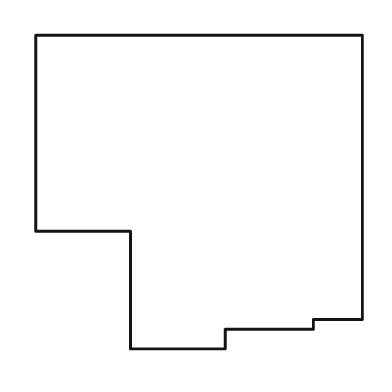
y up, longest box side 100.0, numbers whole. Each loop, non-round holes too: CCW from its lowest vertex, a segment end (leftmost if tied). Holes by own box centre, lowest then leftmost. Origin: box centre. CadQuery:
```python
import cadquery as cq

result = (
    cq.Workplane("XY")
    .moveTo(-21.0, -48.0)
    .lineTo(8.0, -48.0)
    .lineTo(8.0, -42.0)
    .lineTo(35.0, -42.0)
    .lineTo(35.0, -39.0)
    .lineTo(50.0, -39.0)
    .lineTo(50.0, 48.0)
    .lineTo(-50.0, 48.0)
    .lineTo(-50.0, -12.0)
    .lineTo(-21.0, -12.0)
    .close()
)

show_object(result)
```